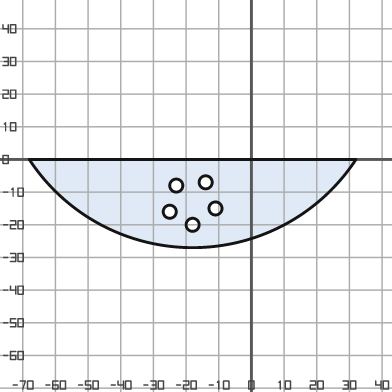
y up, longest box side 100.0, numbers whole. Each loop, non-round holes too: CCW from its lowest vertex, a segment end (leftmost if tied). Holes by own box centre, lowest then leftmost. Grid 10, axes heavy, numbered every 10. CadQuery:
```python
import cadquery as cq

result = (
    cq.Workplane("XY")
    .moveTo(-68.0, 0.0)
    .threePointArc((-18.0, -27.0), (32.0, 0.0))
    .close()
    .moveTo(-18.0, -20.0)
    .circle(2.0)
    .moveTo(-25.0, -16.0)
    .circle(2.0)
    .moveTo(-11.0, -15.0)
    .circle(2.0)
    .moveTo(-23.0, -8.0)
    .circle(2.0)
    .moveTo(-14.0, -7.0)
    .circle(2.0)
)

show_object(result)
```